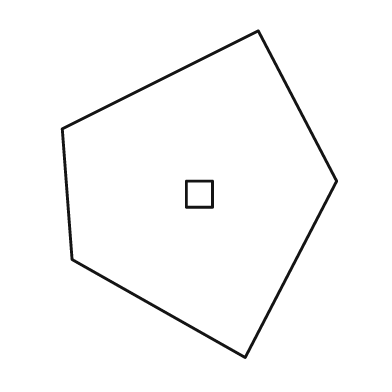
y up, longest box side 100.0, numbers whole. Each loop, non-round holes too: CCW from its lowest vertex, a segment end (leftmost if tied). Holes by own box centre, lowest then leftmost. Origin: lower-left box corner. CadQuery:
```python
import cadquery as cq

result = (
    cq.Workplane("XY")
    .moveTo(56.0, 0.0)
    .lineTo(84.0, 54.0)
    .lineTo(60.0, 100.0)
    .lineTo(0.0, 70.0)
    .lineTo(3.0, 30.0)
    .close()
    .moveTo(38.0, 46.0)
    .lineTo(46.0, 46.0)
    .lineTo(46.0, 54.0)
    .lineTo(38.0, 54.0)
    .close()
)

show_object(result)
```